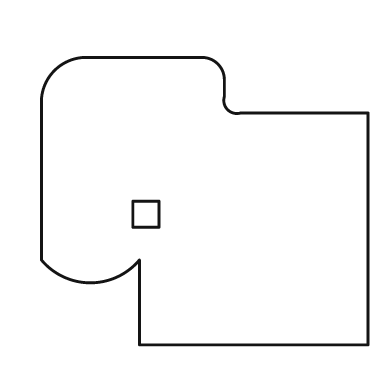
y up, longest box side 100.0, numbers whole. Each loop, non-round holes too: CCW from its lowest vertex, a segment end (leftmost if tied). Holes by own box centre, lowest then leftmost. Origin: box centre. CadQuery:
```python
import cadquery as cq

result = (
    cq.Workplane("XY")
    .moveTo(-20.0, -44.0)
    .lineTo(50.0, -44.0)
    .lineTo(50.0, 27.0)
    .lineTo(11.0, 27.0)
    .threePointArc((7.0, 28.0), (6.0, 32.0))
    .lineTo(6.0, 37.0)
    .threePointArc((4.0, 42.0), (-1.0, 44.0))
    .lineTo(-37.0, 44.0)
    .threePointArc((-46.0, 40.0), (-50.0, 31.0))
    .lineTo(-50.0, -18.0)
    .threePointArc((-35.0, -25.0), (-20.0, -18.0))
    .close()
    .moveTo(-22.0, -8.0)
    .lineTo(-14.0, -8.0)
    .lineTo(-14.0, 0.0)
    .lineTo(-22.0, 0.0)
    .close()
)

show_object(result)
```